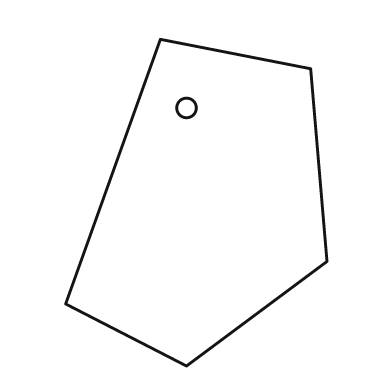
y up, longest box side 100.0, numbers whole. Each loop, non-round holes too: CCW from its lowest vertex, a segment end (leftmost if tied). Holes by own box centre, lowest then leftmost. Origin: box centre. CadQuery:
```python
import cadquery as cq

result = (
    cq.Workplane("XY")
    .moveTo(-3.0, -50.0)
    .lineTo(40.0, -18.0)
    .lineTo(35.0, 41.0)
    .lineTo(-11.0, 50.0)
    .lineTo(-40.0, -31.0)
    .close()
    .moveTo(-3.0, 29.0)
    .circle(3.0)
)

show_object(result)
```